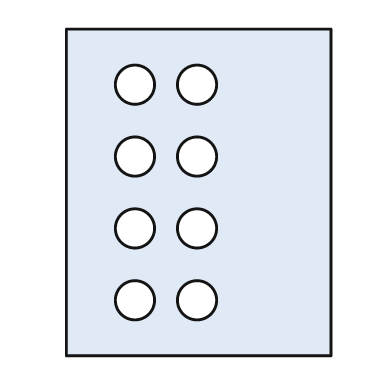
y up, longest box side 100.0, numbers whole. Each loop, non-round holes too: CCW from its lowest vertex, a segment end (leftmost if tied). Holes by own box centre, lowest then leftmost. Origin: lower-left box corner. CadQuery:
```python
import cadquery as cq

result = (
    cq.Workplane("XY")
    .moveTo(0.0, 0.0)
    .lineTo(81.0, 0.0)
    .lineTo(81.0, 100.0)
    .lineTo(0.0, 100.0)
    .close()
    .moveTo(21.0, 17.0)
    .circle(6.0)
    .moveTo(40.0, 17.0)
    .circle(6.0)
    .moveTo(21.0, 39.0)
    .circle(6.0)
    .moveTo(40.0, 39.0)
    .circle(6.0)
    .moveTo(21.0, 61.0)
    .circle(6.0)
    .moveTo(40.0, 61.0)
    .circle(6.0)
    .moveTo(21.0, 83.0)
    .circle(6.0)
    .moveTo(40.0, 83.0)
    .circle(6.0)
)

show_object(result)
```